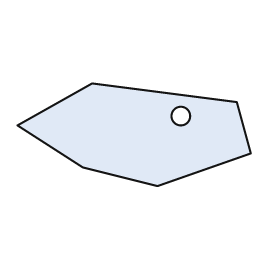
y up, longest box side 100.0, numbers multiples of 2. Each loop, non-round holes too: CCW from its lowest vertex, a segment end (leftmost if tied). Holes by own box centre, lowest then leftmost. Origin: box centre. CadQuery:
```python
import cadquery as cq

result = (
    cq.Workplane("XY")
    .moveTo(10.0, -22.0)
    .lineTo(50.0, -8.0)
    .lineTo(44.0, 14.0)
    .lineTo(-18.0, 22.0)
    .lineTo(-50.0, 4.0)
    .lineTo(-22.0, -14.0)
    .close()
    .moveTo(20.0, 8.0)
    .circle(4.0)
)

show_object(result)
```